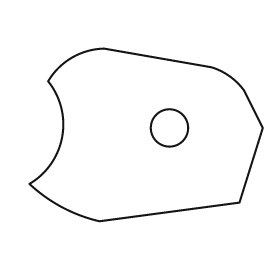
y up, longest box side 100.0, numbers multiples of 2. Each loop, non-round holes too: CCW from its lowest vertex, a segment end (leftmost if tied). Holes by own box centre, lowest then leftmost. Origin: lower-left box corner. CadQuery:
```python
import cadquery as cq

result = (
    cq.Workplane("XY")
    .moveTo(30.0, 0.0)
    .lineTo(90.0, 8.0)
    .lineTo(100.0, 40.0)
    .lineTo(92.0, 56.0)
    .threePointArc((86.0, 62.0), (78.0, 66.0))
    .lineTo(32.0, 74.0)
    .threePointArc((18.0, 70.0), (8.0, 60.0))
    .threePointArc((14.0, 36.0), (0.0, 16.0))
    .threePointArc((14.0, 6.0), (30.0, 0.0))
    .close()
    .moveTo(60.0, 40.0)
    .circle(8.0)
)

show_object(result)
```